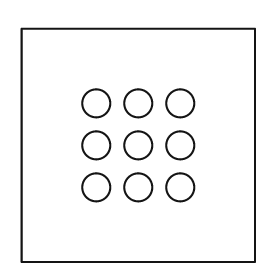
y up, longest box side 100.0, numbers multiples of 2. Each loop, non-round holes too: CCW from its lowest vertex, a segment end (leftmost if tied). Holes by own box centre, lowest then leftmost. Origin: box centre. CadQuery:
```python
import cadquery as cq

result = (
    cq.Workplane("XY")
    .moveTo(-50.0, -50.0)
    .lineTo(50.0, -50.0)
    .lineTo(50.0, 50.0)
    .lineTo(-50.0, 50.0)
    .close()
    .moveTo(-18.0, -18.0)
    .circle(6.0)
    .moveTo(0.0, -18.0)
    .circle(6.0)
    .moveTo(18.0, -18.0)
    .circle(6.0)
    .moveTo(-18.0, 0.0)
    .circle(6.0)
    .moveTo(0.0, 0.0)
    .circle(6.0)
    .moveTo(18.0, 0.0)
    .circle(6.0)
    .moveTo(-18.0, 18.0)
    .circle(6.0)
    .moveTo(0.0, 18.0)
    .circle(6.0)
    .moveTo(18.0, 18.0)
    .circle(6.0)
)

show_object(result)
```